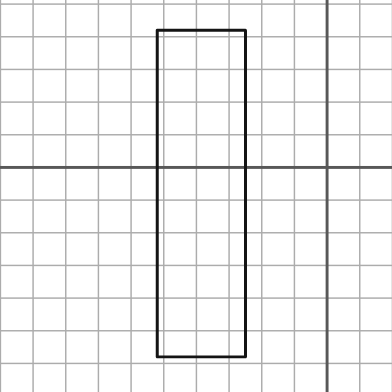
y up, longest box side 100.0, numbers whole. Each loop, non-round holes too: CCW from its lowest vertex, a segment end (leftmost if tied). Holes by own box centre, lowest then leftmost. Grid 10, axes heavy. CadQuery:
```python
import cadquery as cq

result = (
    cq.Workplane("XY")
    .moveTo(-52.0, -58.0)
    .lineTo(-25.0, -58.0)
    .lineTo(-25.0, 42.0)
    .lineTo(-52.0, 42.0)
    .close()
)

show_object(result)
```